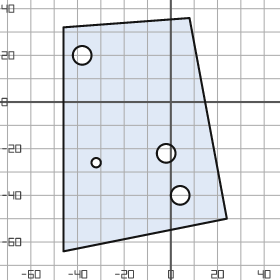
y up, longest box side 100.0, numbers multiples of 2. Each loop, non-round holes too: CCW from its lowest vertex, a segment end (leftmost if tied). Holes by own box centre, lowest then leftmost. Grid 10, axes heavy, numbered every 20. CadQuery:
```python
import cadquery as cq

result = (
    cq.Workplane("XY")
    .moveTo(-46.0, -64.0)
    .lineTo(24.0, -50.0)
    .lineTo(8.0, 36.0)
    .lineTo(-46.0, 32.0)
    .close()
    .moveTo(4.0, -40.0)
    .circle(4.0)
    .moveTo(-32.0, -26.0)
    .circle(2.0)
    .moveTo(-2.0, -22.0)
    .circle(4.0)
    .moveTo(-38.0, 20.0)
    .circle(4.0)
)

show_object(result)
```